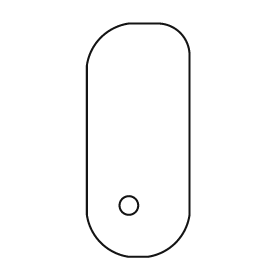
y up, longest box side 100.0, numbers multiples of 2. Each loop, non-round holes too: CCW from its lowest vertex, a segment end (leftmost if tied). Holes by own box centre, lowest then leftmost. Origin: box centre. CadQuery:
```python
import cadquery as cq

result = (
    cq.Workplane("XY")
    .moveTo(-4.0, -50.0)
    .lineTo(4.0, -50.0)
    .threePointArc((16.0, -44.0), (22.0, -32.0))
    .lineTo(22.0, 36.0)
    .threePointArc((18.0, 46.0), (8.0, 50.0))
    .lineTo(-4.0, 50.0)
    .threePointArc((-16.0, 44.0), (-22.0, 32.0))
    .lineTo(-22.0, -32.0)
    .threePointArc((-16.0, -44.0), (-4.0, -50.0))
    .close()
    .moveTo(-4.0, -28.0)
    .circle(4.0)
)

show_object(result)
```